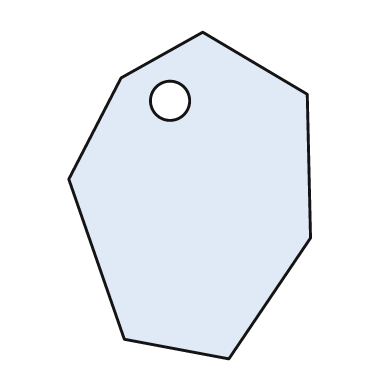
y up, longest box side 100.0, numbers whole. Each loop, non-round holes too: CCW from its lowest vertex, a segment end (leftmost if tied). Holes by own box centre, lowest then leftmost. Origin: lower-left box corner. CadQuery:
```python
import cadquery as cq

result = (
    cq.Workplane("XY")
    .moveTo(49.0, 0.0)
    .lineTo(74.0, 37.0)
    .lineTo(73.0, 81.0)
    .lineTo(41.0, 100.0)
    .lineTo(16.0, 86.0)
    .lineTo(0.0, 55.0)
    .lineTo(17.0, 6.0)
    .close()
    .moveTo(31.0, 79.0)
    .circle(6.0)
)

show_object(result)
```